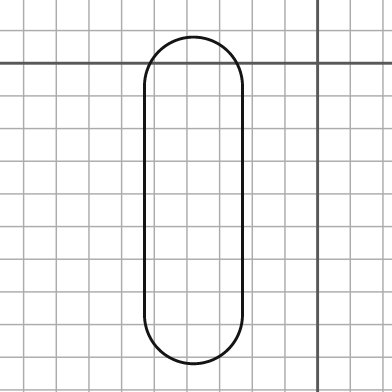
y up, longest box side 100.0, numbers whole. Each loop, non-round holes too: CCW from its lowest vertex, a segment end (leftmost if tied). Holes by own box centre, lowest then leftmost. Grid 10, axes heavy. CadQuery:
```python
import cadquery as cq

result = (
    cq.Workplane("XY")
    .moveTo(-53.0, -77.0)
    .threePointArc((-38.0, -92.0), (-23.0, -77.0))
    .lineTo(-23.0, -7.0)
    .threePointArc((-38.0, 8.0), (-53.0, -7.0))
    .close()
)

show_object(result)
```